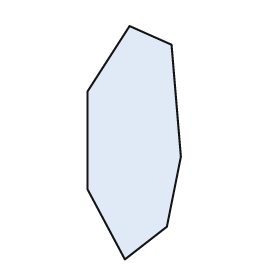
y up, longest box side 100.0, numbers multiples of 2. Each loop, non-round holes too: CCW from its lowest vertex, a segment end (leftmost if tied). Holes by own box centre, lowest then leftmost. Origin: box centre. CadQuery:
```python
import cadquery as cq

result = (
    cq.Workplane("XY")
    .moveTo(-4.0, -50.0)
    .lineTo(14.0, -36.0)
    .lineTo(20.0, -6.0)
    .lineTo(16.0, 42.0)
    .lineTo(-2.0, 50.0)
    .lineTo(-20.0, 22.0)
    .lineTo(-20.0, -20.0)
    .close()
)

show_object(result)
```